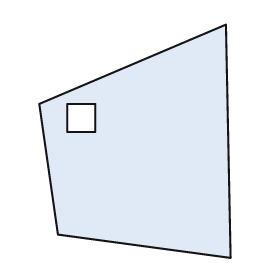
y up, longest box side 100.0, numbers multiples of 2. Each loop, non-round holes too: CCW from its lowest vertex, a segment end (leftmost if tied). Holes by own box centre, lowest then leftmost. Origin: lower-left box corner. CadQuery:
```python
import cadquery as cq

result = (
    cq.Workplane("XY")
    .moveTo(82.0, 0.0)
    .lineTo(80.0, 100.0)
    .lineTo(0.0, 66.0)
    .lineTo(8.0, 10.0)
    .close()
    .moveTo(12.0, 54.0)
    .lineTo(24.0, 54.0)
    .lineTo(24.0, 66.0)
    .lineTo(12.0, 66.0)
    .close()
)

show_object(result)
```